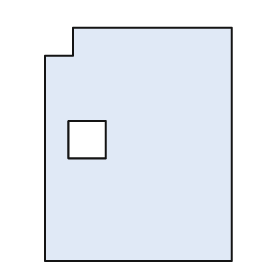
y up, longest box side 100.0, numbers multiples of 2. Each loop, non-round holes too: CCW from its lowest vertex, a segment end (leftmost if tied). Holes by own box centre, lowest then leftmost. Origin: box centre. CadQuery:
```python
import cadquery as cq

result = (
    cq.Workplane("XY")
    .moveTo(-40.0, -50.0)
    .lineTo(40.0, -50.0)
    .lineTo(40.0, 50.0)
    .lineTo(-28.0, 50.0)
    .lineTo(-28.0, 38.0)
    .lineTo(-40.0, 38.0)
    .close()
    .moveTo(-30.0, -6.0)
    .lineTo(-14.0, -6.0)
    .lineTo(-14.0, 10.0)
    .lineTo(-30.0, 10.0)
    .close()
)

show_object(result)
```